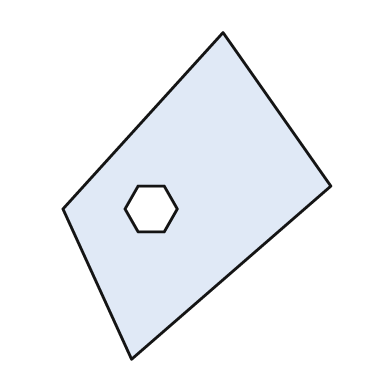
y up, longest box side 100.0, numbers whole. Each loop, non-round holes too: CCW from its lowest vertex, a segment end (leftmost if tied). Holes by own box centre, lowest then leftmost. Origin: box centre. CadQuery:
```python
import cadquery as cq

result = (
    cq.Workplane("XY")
    .moveTo(-20.0, -50.0)
    .lineTo(41.0, 3.0)
    .lineTo(8.0, 50.0)
    .lineTo(-41.0, -4.0)
    .close()
    .moveTo(-18.0, -11.0)
    .lineTo(-10.0, -11.0)
    .lineTo(-6.0, -4.0)
    .lineTo(-10.0, 3.0)
    .lineTo(-18.0, 3.0)
    .lineTo(-22.0, -4.0)
    .close()
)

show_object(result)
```